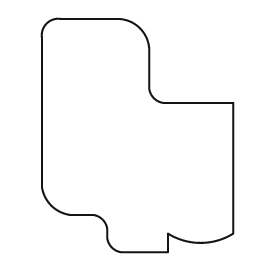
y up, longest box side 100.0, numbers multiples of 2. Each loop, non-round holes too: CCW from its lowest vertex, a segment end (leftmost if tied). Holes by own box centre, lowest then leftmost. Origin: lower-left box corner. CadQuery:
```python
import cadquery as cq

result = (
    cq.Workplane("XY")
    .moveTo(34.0, 0.0)
    .lineTo(54.0, 0.0)
    .lineTo(54.0, 8.0)
    .threePointArc((68.0, 4.0), (82.0, 8.0))
    .lineTo(82.0, 64.0)
    .lineTo(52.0, 64.0)
    .threePointArc((48.0, 66.0), (46.0, 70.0))
    .lineTo(46.0, 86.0)
    .threePointArc((42.0, 96.0), (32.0, 100.0))
    .lineTo(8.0, 100.0)
    .threePointArc((2.0, 98.0), (0.0, 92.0))
    .lineTo(0.0, 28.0)
    .threePointArc((4.0, 20.0), (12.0, 16.0))
    .lineTo(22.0, 16.0)
    .threePointArc((26.0, 14.0), (28.0, 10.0))
    .lineTo(28.0, 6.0)
    .threePointArc((30.0, 2.0), (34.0, 0.0))
    .close()
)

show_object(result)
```